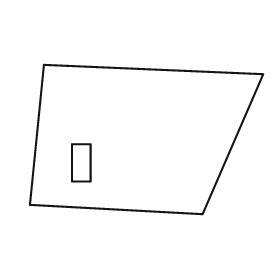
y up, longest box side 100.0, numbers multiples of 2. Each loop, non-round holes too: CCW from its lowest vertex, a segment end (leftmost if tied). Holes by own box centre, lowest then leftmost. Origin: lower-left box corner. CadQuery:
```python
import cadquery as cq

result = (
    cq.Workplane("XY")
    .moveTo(74.0, 0.0)
    .lineTo(100.0, 60.0)
    .lineTo(6.0, 64.0)
    .lineTo(0.0, 4.0)
    .close()
    .moveTo(18.0, 14.0)
    .lineTo(26.0, 14.0)
    .lineTo(26.0, 30.0)
    .lineTo(18.0, 30.0)
    .close()
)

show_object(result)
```